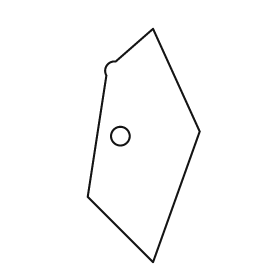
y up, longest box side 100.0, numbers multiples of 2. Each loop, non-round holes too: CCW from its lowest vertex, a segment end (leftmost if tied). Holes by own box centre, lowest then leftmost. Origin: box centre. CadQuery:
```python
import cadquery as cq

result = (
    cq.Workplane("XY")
    .moveTo(4.0, -50.0)
    .lineTo(24.0, 6.0)
    .lineTo(4.0, 50.0)
    .lineTo(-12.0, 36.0)
    .threePointArc((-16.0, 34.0), (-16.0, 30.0))
    .lineTo(-24.0, -22.0)
    .close()
    .moveTo(-10.0, 4.0)
    .circle(4.0)
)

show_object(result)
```